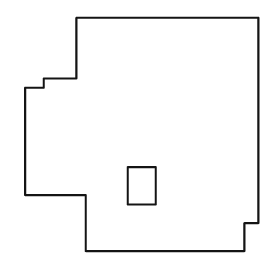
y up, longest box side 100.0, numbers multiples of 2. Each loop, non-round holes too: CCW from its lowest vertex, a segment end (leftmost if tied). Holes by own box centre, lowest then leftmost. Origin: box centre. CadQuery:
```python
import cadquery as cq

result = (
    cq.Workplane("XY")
    .moveTo(-24.0, -50.0)
    .lineTo(44.0, -50.0)
    .lineTo(44.0, -38.0)
    .lineTo(50.0, -38.0)
    .lineTo(50.0, 50.0)
    .lineTo(-28.0, 50.0)
    .lineTo(-28.0, 24.0)
    .lineTo(-42.0, 24.0)
    .lineTo(-42.0, 20.0)
    .lineTo(-50.0, 20.0)
    .lineTo(-50.0, -26.0)
    .lineTo(-24.0, -26.0)
    .close()
    .moveTo(-6.0, -30.0)
    .lineTo(6.0, -30.0)
    .lineTo(6.0, -14.0)
    .lineTo(-6.0, -14.0)
    .close()
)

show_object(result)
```